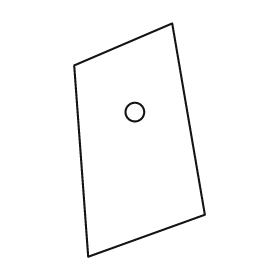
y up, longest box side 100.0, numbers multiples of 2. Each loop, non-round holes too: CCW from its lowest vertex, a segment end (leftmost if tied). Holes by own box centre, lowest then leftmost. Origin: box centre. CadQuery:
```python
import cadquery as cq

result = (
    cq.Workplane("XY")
    .moveTo(-22.0, -50.0)
    .lineTo(28.0, -32.0)
    .lineTo(14.0, 50.0)
    .lineTo(-28.0, 32.0)
    .close()
    .moveTo(-2.0, 12.0)
    .circle(4.0)
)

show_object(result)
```